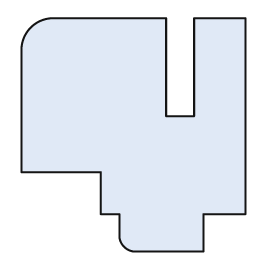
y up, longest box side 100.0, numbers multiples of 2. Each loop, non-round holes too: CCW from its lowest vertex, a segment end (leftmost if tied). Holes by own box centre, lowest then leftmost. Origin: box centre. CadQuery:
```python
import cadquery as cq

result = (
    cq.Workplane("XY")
    .moveTo(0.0, -50.0)
    .lineTo(30.0, -50.0)
    .lineTo(30.0, -34.0)
    .lineTo(48.0, -34.0)
    .lineTo(48.0, 50.0)
    .lineTo(26.0, 50.0)
    .lineTo(26.0, 8.0)
    .lineTo(14.0, 8.0)
    .lineTo(14.0, 50.0)
    .lineTo(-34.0, 50.0)
    .threePointArc((-44.0, 46.0), (-48.0, 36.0))
    .lineTo(-48.0, -16.0)
    .lineTo(-14.0, -16.0)
    .lineTo(-14.0, -34.0)
    .lineTo(-6.0, -34.0)
    .lineTo(-6.0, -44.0)
    .threePointArc((-4.0, -48.0), (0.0, -50.0))
    .close()
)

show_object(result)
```